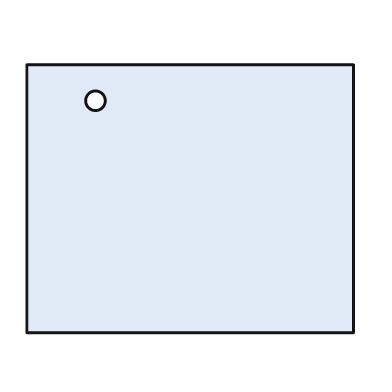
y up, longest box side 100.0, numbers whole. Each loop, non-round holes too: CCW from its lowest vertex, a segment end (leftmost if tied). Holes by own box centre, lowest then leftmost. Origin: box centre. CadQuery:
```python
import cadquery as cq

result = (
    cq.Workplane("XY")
    .moveTo(-50.0, -41.0)
    .lineTo(50.0, -41.0)
    .lineTo(50.0, 41.0)
    .lineTo(-50.0, 41.0)
    .close()
    .moveTo(-29.0, 30.0)
    .circle(3.0)
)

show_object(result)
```